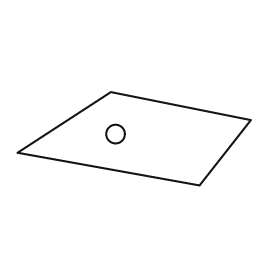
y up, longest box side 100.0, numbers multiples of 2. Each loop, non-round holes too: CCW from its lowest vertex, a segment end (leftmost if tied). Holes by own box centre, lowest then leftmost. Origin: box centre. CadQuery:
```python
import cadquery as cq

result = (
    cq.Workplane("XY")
    .moveTo(28.0, -20.0)
    .lineTo(50.0, 8.0)
    .lineTo(-10.0, 20.0)
    .lineTo(-50.0, -6.0)
    .close()
    .moveTo(-8.0, 2.0)
    .circle(4.0)
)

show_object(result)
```